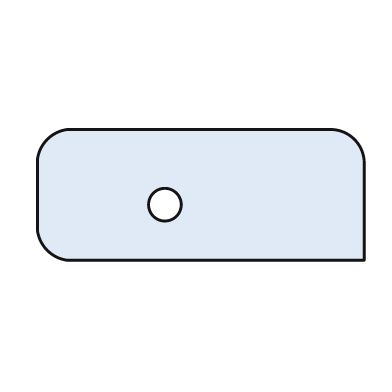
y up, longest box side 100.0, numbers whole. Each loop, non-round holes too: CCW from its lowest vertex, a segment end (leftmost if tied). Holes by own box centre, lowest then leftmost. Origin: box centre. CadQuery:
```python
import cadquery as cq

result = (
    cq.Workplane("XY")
    .moveTo(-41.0, -20.0)
    .lineTo(50.0, -20.0)
    .lineTo(50.0, 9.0)
    .threePointArc((47.0, 17.0), (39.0, 20.0))
    .lineTo(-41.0, 20.0)
    .threePointArc((-47.0, 17.0), (-50.0, 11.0))
    .lineTo(-50.0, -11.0)
    .threePointArc((-47.0, -17.0), (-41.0, -20.0))
    .close()
    .moveTo(-11.0, -3.0)
    .circle(5.0)
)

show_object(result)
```